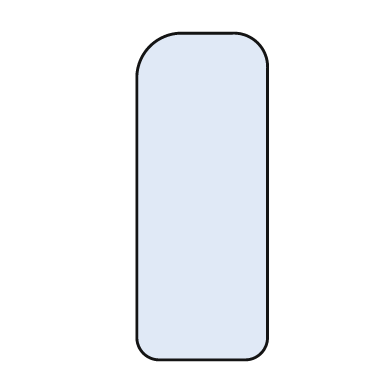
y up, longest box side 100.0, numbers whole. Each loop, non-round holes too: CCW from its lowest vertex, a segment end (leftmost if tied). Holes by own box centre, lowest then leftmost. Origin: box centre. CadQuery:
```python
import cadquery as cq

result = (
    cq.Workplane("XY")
    .moveTo(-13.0, -50.0)
    .lineTo(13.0, -50.0)
    .threePointArc((18.0, -48.0), (20.0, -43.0))
    .lineTo(20.0, 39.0)
    .threePointArc((17.0, 47.0), (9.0, 50.0))
    .lineTo(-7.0, 50.0)
    .threePointArc((-16.0, 46.0), (-20.0, 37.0))
    .lineTo(-20.0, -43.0)
    .threePointArc((-18.0, -48.0), (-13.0, -50.0))
    .close()
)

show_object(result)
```